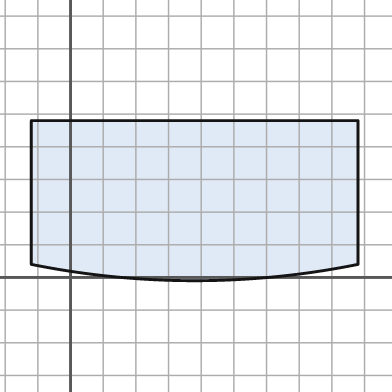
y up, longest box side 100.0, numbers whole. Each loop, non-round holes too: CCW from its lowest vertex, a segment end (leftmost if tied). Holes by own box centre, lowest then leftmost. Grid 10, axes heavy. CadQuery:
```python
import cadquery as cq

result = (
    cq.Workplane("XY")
    .moveTo(-12.0, 4.0)
    .threePointArc((38.0, -1.0), (88.0, 4.0))
    .lineTo(88.0, 48.0)
    .lineTo(-12.0, 48.0)
    .close()
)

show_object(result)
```